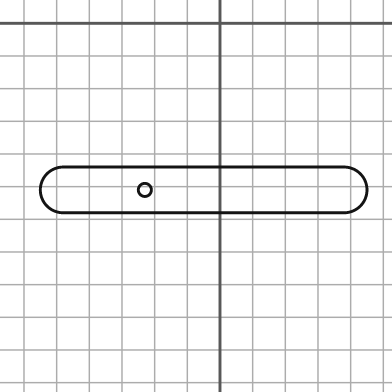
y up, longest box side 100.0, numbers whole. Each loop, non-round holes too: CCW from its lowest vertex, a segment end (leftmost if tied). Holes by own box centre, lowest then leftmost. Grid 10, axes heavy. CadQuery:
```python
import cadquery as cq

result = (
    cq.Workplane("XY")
    .moveTo(-48.0, -58.0)
    .lineTo(38.0, -58.0)
    .threePointArc((45.0, -51.0), (38.0, -44.0))
    .lineTo(-48.0, -44.0)
    .threePointArc((-55.0, -51.0), (-48.0, -58.0))
    .close()
    .moveTo(-23.0, -51.0)
    .circle(2.0)
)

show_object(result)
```